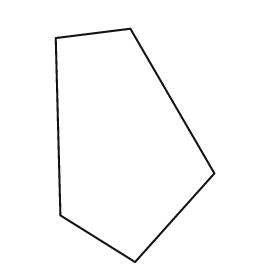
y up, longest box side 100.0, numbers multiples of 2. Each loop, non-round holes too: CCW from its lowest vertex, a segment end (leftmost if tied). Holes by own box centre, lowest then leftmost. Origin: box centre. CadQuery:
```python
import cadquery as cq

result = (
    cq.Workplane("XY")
    .moveTo(0.0, -50.0)
    .lineTo(34.0, -12.0)
    .lineTo(-2.0, 50.0)
    .lineTo(-34.0, 46.0)
    .lineTo(-32.0, -30.0)
    .close()
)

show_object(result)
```